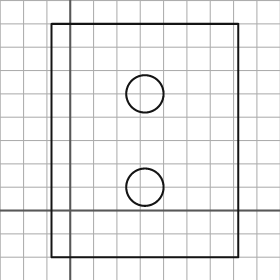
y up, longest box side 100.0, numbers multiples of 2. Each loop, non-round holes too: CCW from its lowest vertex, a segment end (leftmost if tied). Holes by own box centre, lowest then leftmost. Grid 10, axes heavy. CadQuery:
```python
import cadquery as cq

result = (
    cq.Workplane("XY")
    .moveTo(-8.0, -20.0)
    .lineTo(72.0, -20.0)
    .lineTo(72.0, 80.0)
    .lineTo(-8.0, 80.0)
    .close()
    .moveTo(32.0, 10.0)
    .circle(8.0)
    .moveTo(32.0, 50.0)
    .circle(8.0)
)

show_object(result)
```